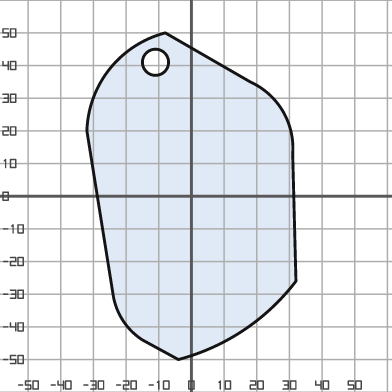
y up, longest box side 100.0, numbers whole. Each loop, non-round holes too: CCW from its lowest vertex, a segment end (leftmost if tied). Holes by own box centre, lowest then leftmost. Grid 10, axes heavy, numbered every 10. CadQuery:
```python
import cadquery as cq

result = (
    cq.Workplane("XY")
    .moveTo(-4.0, -50.0)
    .threePointArc((16.0, -41.0), (32.0, -26.0))
    .lineTo(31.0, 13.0)
    .threePointArc((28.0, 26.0), (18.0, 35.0))
    .lineTo(-8.0, 50.0)
    .threePointArc((-25.0, 39.0), (-32.0, 20.0))
    .lineTo(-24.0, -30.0)
    .threePointArc((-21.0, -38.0), (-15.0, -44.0))
    .close()
    .moveTo(-11.0, 41.0)
    .circle(4.0)
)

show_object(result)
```